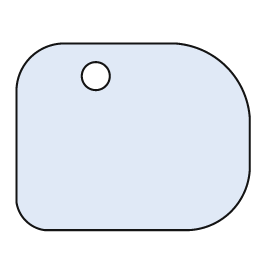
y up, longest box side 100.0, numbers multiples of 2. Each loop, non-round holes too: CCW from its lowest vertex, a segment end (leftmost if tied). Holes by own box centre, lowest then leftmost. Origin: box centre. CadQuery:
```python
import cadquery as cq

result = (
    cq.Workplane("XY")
    .moveTo(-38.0, -40.0)
    .lineTo(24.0, -40.0)
    .threePointArc((42.0, -32.0), (50.0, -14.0))
    .lineTo(50.0, 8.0)
    .threePointArc((40.0, 30.0), (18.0, 40.0))
    .lineTo(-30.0, 40.0)
    .threePointArc((-44.0, 34.0), (-50.0, 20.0))
    .lineTo(-50.0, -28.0)
    .threePointArc((-46.0, -36.0), (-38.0, -40.0))
    .close()
    .moveTo(-16.0, 26.0)
    .circle(6.0)
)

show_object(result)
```